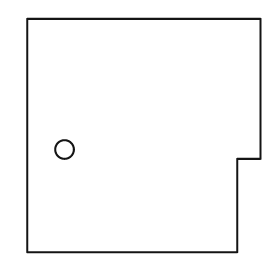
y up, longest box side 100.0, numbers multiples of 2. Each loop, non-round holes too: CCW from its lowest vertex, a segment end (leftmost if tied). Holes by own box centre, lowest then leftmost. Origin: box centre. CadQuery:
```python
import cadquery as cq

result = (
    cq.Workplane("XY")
    .moveTo(-50.0, -50.0)
    .lineTo(40.0, -50.0)
    .lineTo(40.0, -10.0)
    .lineTo(50.0, -10.0)
    .lineTo(50.0, 50.0)
    .lineTo(-50.0, 50.0)
    .close()
    .moveTo(-34.0, -6.0)
    .circle(4.0)
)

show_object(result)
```